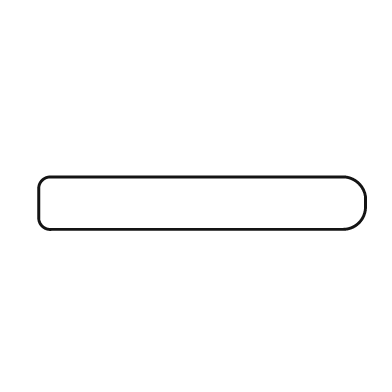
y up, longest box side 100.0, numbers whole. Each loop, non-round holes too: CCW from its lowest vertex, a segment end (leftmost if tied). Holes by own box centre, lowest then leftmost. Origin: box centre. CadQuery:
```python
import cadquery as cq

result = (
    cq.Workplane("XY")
    .moveTo(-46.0, -8.0)
    .lineTo(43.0, -8.0)
    .threePointArc((48.0, -6.0), (50.0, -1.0))
    .lineTo(50.0, 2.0)
    .threePointArc((48.0, 6.0), (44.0, 8.0))
    .lineTo(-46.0, 8.0)
    .threePointArc((-49.0, 7.0), (-50.0, 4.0))
    .lineTo(-50.0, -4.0)
    .threePointArc((-49.0, -7.0), (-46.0, -8.0))
    .close()
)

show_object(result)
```